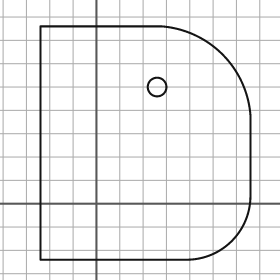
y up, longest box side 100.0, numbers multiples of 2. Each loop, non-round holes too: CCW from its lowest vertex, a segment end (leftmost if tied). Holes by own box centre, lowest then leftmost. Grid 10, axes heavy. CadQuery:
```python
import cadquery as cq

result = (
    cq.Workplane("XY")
    .moveTo(-24.0, -24.0)
    .lineTo(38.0, -24.0)
    .threePointArc((58.0, -16.0), (66.0, 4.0))
    .lineTo(66.0, 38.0)
    .threePointArc((54.0, 64.0), (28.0, 76.0))
    .lineTo(-24.0, 76.0)
    .close()
    .moveTo(26.0, 50.0)
    .circle(4.0)
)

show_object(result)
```